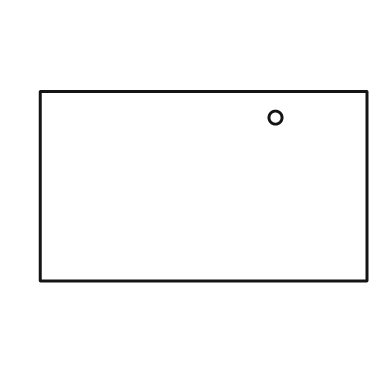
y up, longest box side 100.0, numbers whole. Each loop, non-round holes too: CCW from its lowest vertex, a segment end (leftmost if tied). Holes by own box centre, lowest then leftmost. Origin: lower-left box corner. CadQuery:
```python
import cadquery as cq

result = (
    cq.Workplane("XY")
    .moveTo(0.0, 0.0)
    .lineTo(100.0, 0.0)
    .lineTo(100.0, 58.0)
    .lineTo(0.0, 58.0)
    .close()
    .moveTo(72.0, 50.0)
    .circle(2.0)
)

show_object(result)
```